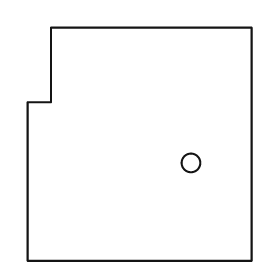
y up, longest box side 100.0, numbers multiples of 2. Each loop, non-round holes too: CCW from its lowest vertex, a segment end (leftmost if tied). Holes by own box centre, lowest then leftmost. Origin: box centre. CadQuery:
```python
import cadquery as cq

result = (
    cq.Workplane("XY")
    .moveTo(-48.0, -50.0)
    .lineTo(48.0, -50.0)
    .lineTo(48.0, 50.0)
    .lineTo(-38.0, 50.0)
    .lineTo(-38.0, 18.0)
    .lineTo(-48.0, 18.0)
    .close()
    .moveTo(22.0, -8.0)
    .circle(4.0)
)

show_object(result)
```